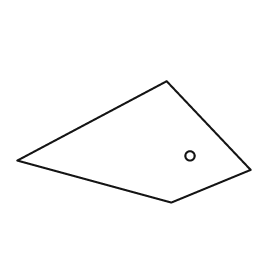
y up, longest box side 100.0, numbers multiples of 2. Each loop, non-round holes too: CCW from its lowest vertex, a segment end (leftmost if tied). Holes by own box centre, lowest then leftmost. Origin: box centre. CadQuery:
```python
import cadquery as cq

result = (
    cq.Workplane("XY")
    .moveTo(16.0, -26.0)
    .lineTo(50.0, -12.0)
    .lineTo(14.0, 26.0)
    .lineTo(-50.0, -8.0)
    .close()
    .moveTo(24.0, -6.0)
    .circle(2.0)
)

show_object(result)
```